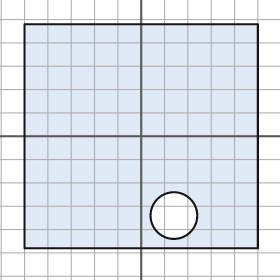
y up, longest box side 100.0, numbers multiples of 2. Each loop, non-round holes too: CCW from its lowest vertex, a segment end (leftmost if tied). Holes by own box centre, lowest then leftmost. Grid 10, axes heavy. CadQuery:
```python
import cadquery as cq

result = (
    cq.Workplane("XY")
    .moveTo(-50.0, -48.0)
    .lineTo(50.0, -48.0)
    .lineTo(50.0, 48.0)
    .lineTo(-50.0, 48.0)
    .close()
    .moveTo(14.0, -34.0)
    .circle(10.0)
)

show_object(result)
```